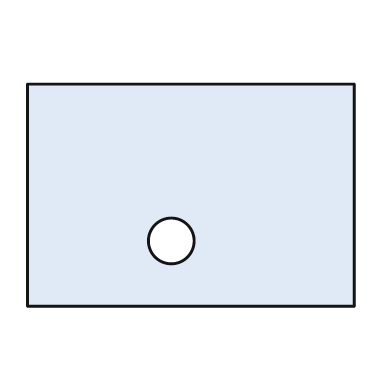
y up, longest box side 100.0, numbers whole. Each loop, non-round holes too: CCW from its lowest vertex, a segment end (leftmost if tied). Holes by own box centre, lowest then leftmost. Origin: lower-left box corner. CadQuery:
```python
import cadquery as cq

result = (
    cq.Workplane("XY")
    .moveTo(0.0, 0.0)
    .lineTo(100.0, 0.0)
    .lineTo(100.0, 68.0)
    .lineTo(0.0, 68.0)
    .close()
    .moveTo(44.0, 20.0)
    .circle(7.0)
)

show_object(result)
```